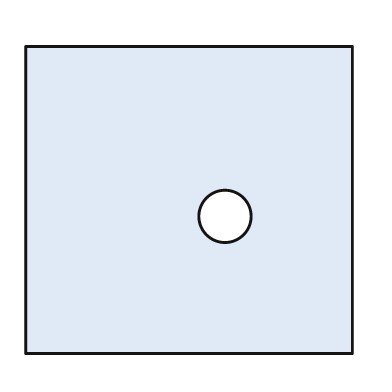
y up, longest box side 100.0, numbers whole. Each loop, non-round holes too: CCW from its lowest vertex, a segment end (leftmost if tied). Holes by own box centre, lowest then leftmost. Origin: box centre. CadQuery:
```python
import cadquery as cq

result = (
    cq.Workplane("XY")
    .moveTo(-50.0, -47.0)
    .lineTo(50.0, -47.0)
    .lineTo(50.0, 47.0)
    .lineTo(-50.0, 47.0)
    .close()
    .moveTo(11.0, -5.0)
    .circle(8.0)
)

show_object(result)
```